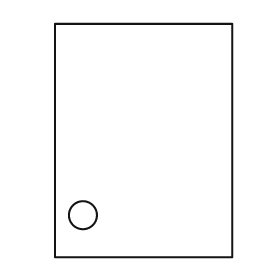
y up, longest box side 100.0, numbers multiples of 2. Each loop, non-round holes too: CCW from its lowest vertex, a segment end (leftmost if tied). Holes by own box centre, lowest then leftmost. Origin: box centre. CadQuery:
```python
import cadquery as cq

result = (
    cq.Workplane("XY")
    .moveTo(-38.0, -50.0)
    .lineTo(38.0, -50.0)
    .lineTo(38.0, 50.0)
    .lineTo(-38.0, 50.0)
    .close()
    .moveTo(-26.0, -32.0)
    .circle(6.0)
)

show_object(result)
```